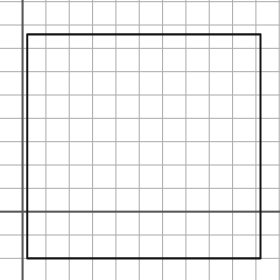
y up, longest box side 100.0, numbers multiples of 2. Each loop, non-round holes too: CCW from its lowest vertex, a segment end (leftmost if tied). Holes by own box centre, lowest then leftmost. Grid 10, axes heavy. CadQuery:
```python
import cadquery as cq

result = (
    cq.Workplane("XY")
    .moveTo(2.0, -20.0)
    .lineTo(102.0, -20.0)
    .lineTo(102.0, 76.0)
    .lineTo(2.0, 76.0)
    .close()
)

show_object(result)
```